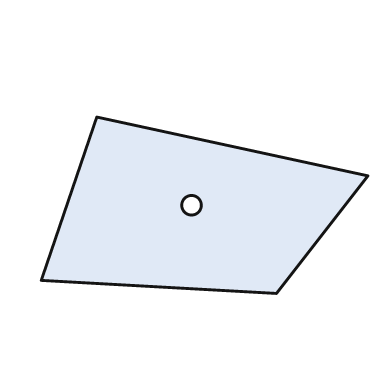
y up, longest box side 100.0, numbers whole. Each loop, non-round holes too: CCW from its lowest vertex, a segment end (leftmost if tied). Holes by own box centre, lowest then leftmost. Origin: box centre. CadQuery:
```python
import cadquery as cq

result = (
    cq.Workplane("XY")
    .moveTo(22.0, -27.0)
    .lineTo(50.0, 9.0)
    .lineTo(-33.0, 27.0)
    .lineTo(-50.0, -23.0)
    .close()
    .moveTo(-4.0, 0.0)
    .circle(3.0)
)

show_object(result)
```